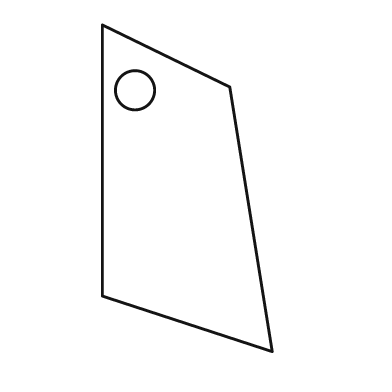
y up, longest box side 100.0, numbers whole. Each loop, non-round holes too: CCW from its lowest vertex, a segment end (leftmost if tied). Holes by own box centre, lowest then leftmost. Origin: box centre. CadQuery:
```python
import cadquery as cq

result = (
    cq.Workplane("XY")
    .moveTo(26.0, -50.0)
    .lineTo(13.0, 31.0)
    .lineTo(-26.0, 50.0)
    .lineTo(-26.0, -33.0)
    .close()
    .moveTo(-16.0, 30.0)
    .circle(6.0)
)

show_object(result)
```